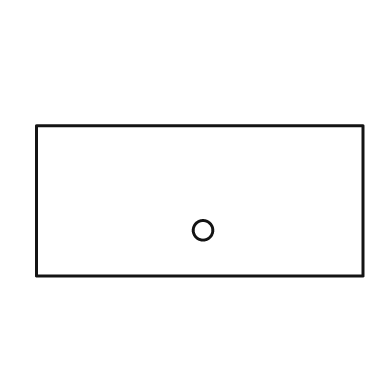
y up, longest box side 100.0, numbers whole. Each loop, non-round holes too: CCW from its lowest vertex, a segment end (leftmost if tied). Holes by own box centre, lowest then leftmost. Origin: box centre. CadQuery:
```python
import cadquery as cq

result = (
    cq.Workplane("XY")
    .moveTo(-50.0, -23.0)
    .lineTo(50.0, -23.0)
    .lineTo(50.0, 23.0)
    .lineTo(-50.0, 23.0)
    .close()
    .moveTo(1.0, -9.0)
    .circle(3.0)
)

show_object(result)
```